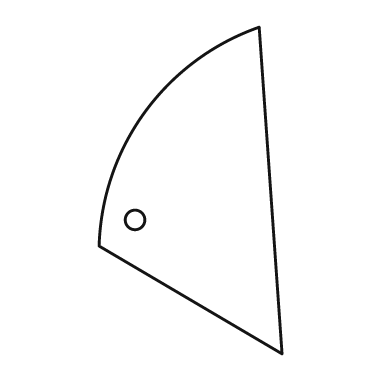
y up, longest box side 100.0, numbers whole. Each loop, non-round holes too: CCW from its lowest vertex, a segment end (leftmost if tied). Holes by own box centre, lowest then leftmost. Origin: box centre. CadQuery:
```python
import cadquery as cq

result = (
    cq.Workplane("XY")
    .moveTo(28.0, -50.0)
    .lineTo(21.0, 50.0)
    .threePointArc((-14.0, 24.0), (-28.0, -17.0))
    .close()
    .moveTo(-17.0, -9.0)
    .circle(3.0)
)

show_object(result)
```